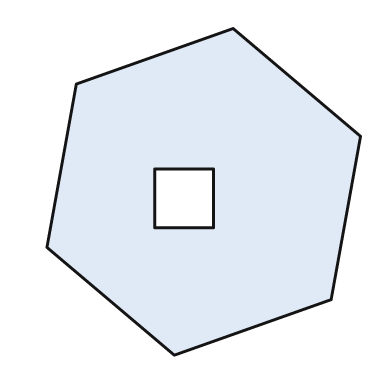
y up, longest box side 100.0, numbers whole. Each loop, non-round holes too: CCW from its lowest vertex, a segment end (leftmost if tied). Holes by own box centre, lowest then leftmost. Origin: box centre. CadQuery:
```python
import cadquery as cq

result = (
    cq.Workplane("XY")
    .moveTo(-9.0, -50.0)
    .lineTo(39.0, -33.0)
    .lineTo(48.0, 17.0)
    .lineTo(9.0, 50.0)
    .lineTo(-39.0, 33.0)
    .lineTo(-48.0, -17.0)
    .close()
    .moveTo(-15.0, -11.0)
    .lineTo(3.0, -11.0)
    .lineTo(3.0, 7.0)
    .lineTo(-15.0, 7.0)
    .close()
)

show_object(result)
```